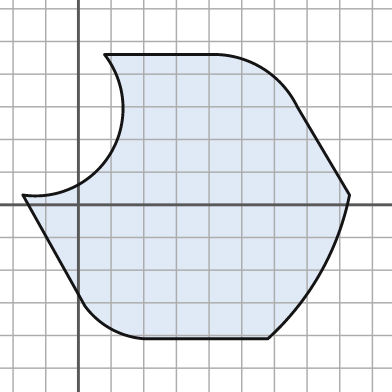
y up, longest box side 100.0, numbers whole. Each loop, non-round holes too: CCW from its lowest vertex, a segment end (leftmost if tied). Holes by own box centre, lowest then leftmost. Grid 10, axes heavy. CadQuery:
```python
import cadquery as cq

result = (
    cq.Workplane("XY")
    .moveTo(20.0, -41.0)
    .lineTo(58.0, -41.0)
    .threePointArc((74.0, -21.0), (83.0, 3.0))
    .lineTo(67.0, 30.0)
    .threePointArc((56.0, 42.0), (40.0, 46.0))
    .lineTo(8.0, 46.0)
    .threePointArc((10.0, 16.0), (-17.0, 3.0))
    .lineTo(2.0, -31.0)
    .threePointArc((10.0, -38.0), (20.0, -41.0))
    .close()
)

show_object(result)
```